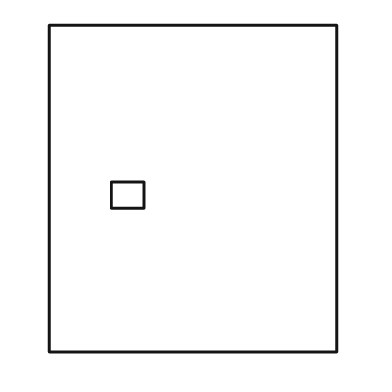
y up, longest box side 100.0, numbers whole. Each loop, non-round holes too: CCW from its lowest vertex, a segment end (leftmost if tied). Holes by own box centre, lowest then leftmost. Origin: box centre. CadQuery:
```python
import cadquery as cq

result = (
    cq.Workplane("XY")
    .moveTo(-44.0, -50.0)
    .lineTo(44.0, -50.0)
    .lineTo(44.0, 50.0)
    .lineTo(-44.0, 50.0)
    .close()
    .moveTo(-25.0, -6.0)
    .lineTo(-15.0, -6.0)
    .lineTo(-15.0, 2.0)
    .lineTo(-25.0, 2.0)
    .close()
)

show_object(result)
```